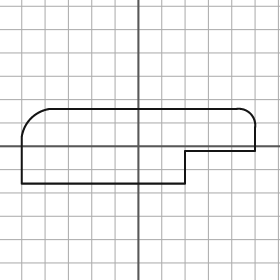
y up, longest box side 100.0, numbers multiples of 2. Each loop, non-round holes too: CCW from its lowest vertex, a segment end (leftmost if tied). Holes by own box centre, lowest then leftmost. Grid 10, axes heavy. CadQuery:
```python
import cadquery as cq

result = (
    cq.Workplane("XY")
    .moveTo(-50.0, -16.0)
    .lineTo(20.0, -16.0)
    .lineTo(20.0, -2.0)
    .lineTo(50.0, -2.0)
    .lineTo(50.0, 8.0)
    .threePointArc((48.0, 14.0), (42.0, 16.0))
    .lineTo(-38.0, 16.0)
    .threePointArc((-46.0, 12.0), (-50.0, 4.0))
    .close()
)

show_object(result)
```